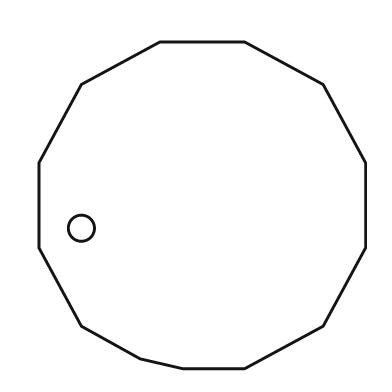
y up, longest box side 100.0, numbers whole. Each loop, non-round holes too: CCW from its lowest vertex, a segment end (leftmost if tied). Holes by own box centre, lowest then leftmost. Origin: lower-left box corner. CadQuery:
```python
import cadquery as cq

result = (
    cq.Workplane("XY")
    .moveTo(44.0, 0.0)
    .lineTo(63.0, 0.0)
    .lineTo(87.0, 13.0)
    .lineTo(100.0, 37.0)
    .lineTo(100.0, 63.0)
    .lineTo(87.0, 87.0)
    .lineTo(63.0, 100.0)
    .lineTo(37.0, 100.0)
    .lineTo(13.0, 87.0)
    .lineTo(0.0, 63.0)
    .lineTo(0.0, 37.0)
    .lineTo(13.0, 13.0)
    .lineTo(31.0, 3.0)
    .close()
    .moveTo(13.0, 43.0)
    .circle(4.0)
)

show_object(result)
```